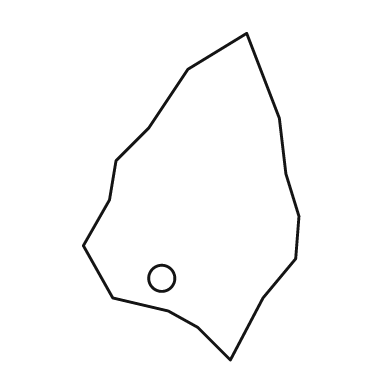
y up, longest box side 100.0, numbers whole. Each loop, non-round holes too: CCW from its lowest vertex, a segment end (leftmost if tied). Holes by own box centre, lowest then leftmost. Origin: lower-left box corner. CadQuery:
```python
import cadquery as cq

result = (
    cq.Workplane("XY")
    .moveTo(45.0, 0.0)
    .lineTo(55.0, 19.0)
    .lineTo(65.0, 31.0)
    .lineTo(66.0, 44.0)
    .lineTo(62.0, 57.0)
    .lineTo(60.0, 74.0)
    .lineTo(50.0, 100.0)
    .lineTo(32.0, 89.0)
    .lineTo(20.0, 71.0)
    .lineTo(10.0, 61.0)
    .lineTo(8.0, 49.0)
    .lineTo(0.0, 35.0)
    .lineTo(9.0, 19.0)
    .lineTo(26.0, 15.0)
    .lineTo(35.0, 10.0)
    .close()
    .moveTo(24.0, 25.0)
    .circle(4.0)
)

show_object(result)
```